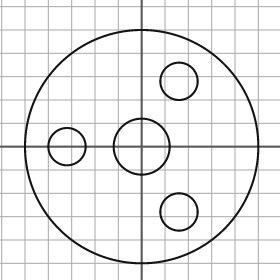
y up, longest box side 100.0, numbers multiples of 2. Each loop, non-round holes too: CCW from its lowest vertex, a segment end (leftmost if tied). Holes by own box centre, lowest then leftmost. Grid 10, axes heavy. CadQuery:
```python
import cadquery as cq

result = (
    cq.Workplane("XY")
    .moveTo(0.0, 0.0)
    .circle(50.0)
    .moveTo(16.0, -28.0)
    .circle(8.0)
    .moveTo(-32.0, 0.0)
    .circle(8.0)
    .moveTo(0.0, 0.0)
    .circle(12.0)
    .moveTo(16.0, 28.0)
    .circle(8.0)
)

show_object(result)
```